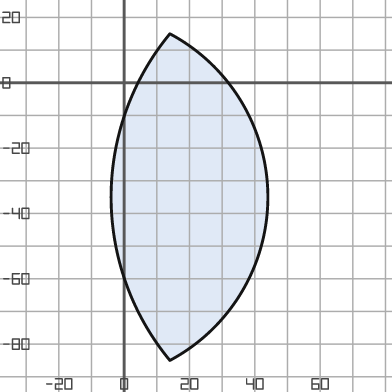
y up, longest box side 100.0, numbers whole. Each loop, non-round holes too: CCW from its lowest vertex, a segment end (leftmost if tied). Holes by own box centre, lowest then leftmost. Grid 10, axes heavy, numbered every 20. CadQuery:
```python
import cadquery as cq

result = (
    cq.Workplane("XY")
    .moveTo(14.0, -85.0)
    .threePointArc((44.0, -35.0), (14.0, 15.0))
    .threePointArc((-4.0, -35.0), (14.0, -85.0))
    .close()
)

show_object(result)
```